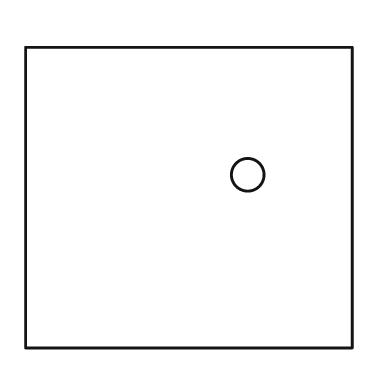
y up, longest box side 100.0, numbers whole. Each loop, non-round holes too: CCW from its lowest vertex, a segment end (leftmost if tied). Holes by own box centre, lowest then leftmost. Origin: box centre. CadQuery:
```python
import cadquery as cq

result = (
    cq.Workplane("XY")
    .moveTo(-50.0, -46.0)
    .lineTo(50.0, -46.0)
    .lineTo(50.0, 46.0)
    .lineTo(-50.0, 46.0)
    .close()
    .moveTo(18.0, 7.0)
    .circle(5.0)
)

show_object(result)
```